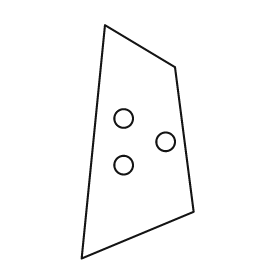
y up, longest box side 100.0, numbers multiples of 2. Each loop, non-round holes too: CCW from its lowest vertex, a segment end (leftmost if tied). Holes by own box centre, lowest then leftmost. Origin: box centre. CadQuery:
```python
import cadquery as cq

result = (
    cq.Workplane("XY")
    .moveTo(-24.0, -50.0)
    .lineTo(24.0, -30.0)
    .lineTo(16.0, 32.0)
    .lineTo(-14.0, 50.0)
    .close()
    .moveTo(-6.0, -10.0)
    .circle(4.0)
    .moveTo(12.0, 0.0)
    .circle(4.0)
    .moveTo(-6.0, 10.0)
    .circle(4.0)
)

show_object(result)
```